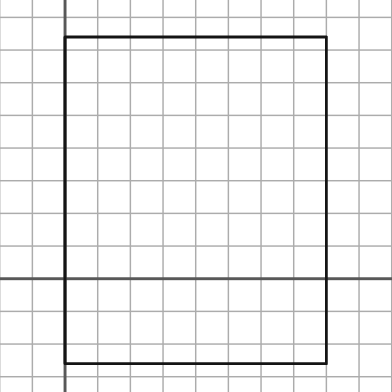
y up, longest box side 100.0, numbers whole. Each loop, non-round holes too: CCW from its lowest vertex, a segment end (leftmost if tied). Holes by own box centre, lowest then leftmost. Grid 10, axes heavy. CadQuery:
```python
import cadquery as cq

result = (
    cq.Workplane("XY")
    .moveTo(0.0, -26.0)
    .lineTo(80.0, -26.0)
    .lineTo(80.0, 74.0)
    .lineTo(0.0, 74.0)
    .close()
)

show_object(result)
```